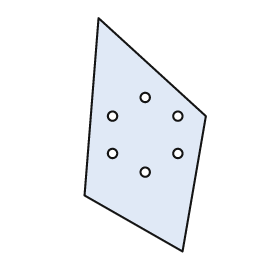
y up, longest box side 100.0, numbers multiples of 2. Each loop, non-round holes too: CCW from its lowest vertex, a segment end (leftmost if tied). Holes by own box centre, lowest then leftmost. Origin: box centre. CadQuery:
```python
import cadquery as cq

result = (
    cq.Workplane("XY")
    .moveTo(16.0, -50.0)
    .lineTo(26.0, 8.0)
    .lineTo(-20.0, 50.0)
    .lineTo(-26.0, -26.0)
    .close()
    .moveTo(0.0, -16.0)
    .circle(2.0)
    .moveTo(-14.0, -8.0)
    .circle(2.0)
    .moveTo(14.0, -8.0)
    .circle(2.0)
    .moveTo(-14.0, 8.0)
    .circle(2.0)
    .moveTo(14.0, 8.0)
    .circle(2.0)
    .moveTo(0.0, 16.0)
    .circle(2.0)
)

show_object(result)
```